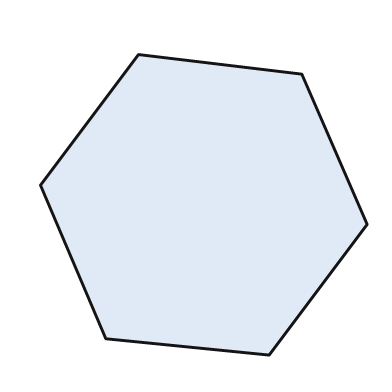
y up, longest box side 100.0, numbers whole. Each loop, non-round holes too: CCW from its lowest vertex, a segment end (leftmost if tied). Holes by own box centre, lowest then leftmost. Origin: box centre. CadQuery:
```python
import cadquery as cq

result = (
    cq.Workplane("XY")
    .moveTo(20.0, -46.0)
    .lineTo(50.0, -6.0)
    .lineTo(30.0, 40.0)
    .lineTo(-20.0, 46.0)
    .lineTo(-50.0, 6.0)
    .lineTo(-30.0, -41.0)
    .close()
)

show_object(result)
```